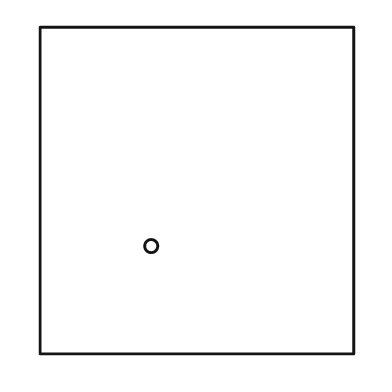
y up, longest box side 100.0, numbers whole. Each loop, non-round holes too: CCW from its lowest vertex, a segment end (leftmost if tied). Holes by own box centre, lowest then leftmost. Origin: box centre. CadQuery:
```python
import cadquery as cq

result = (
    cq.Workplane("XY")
    .moveTo(-48.0, -50.0)
    .lineTo(48.0, -50.0)
    .lineTo(48.0, 50.0)
    .lineTo(-48.0, 50.0)
    .close()
    .moveTo(-14.0, -17.0)
    .circle(2.0)
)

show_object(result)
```